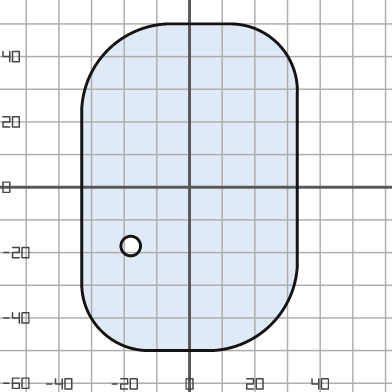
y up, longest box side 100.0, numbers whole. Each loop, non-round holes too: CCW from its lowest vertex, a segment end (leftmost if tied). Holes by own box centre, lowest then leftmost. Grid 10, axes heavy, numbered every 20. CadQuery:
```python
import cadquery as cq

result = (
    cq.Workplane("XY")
    .moveTo(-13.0, -50.0)
    .lineTo(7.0, -50.0)
    .threePointArc((25.0, -42.0), (33.0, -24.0))
    .lineTo(33.0, 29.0)
    .threePointArc((27.0, 44.0), (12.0, 50.0))
    .lineTo(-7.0, 50.0)
    .threePointArc((-25.0, 42.0), (-33.0, 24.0))
    .lineTo(-33.0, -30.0)
    .threePointArc((-27.0, -44.0), (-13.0, -50.0))
    .close()
    .moveTo(-18.0, -18.0)
    .circle(3.0)
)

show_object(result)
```